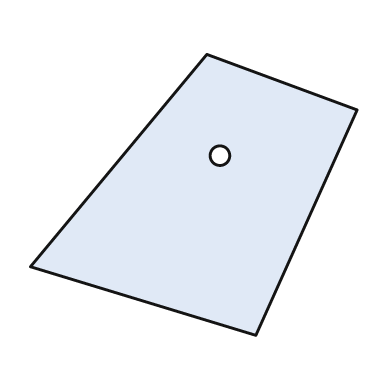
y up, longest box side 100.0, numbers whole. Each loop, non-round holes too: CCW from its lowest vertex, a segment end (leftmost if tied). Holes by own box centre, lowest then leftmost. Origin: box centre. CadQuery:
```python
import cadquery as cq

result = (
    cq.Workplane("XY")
    .moveTo(19.0, -43.0)
    .lineTo(50.0, 26.0)
    .lineTo(4.0, 43.0)
    .lineTo(-50.0, -22.0)
    .close()
    .moveTo(8.0, 12.0)
    .circle(3.0)
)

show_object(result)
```